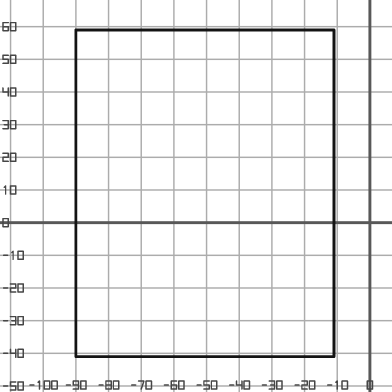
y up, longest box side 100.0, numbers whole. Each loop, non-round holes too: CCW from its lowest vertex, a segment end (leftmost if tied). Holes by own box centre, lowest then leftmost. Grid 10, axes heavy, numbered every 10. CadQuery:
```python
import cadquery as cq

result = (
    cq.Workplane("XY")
    .moveTo(-90.0, -41.0)
    .lineTo(-11.0, -41.0)
    .lineTo(-11.0, 59.0)
    .lineTo(-90.0, 59.0)
    .close()
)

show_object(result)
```